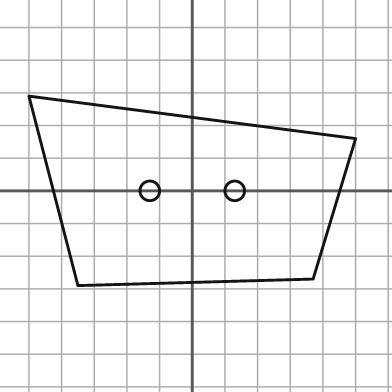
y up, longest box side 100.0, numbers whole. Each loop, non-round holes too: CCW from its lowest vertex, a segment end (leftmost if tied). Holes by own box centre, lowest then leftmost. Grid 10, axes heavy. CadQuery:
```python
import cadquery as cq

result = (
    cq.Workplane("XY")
    .moveTo(-35.0, -29.0)
    .lineTo(37.0, -27.0)
    .lineTo(50.0, 16.0)
    .lineTo(-50.0, 29.0)
    .close()
    .moveTo(-13.0, 0.0)
    .circle(3.0)
    .moveTo(13.0, 0.0)
    .circle(3.0)
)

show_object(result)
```